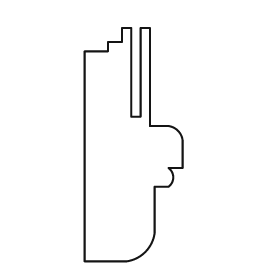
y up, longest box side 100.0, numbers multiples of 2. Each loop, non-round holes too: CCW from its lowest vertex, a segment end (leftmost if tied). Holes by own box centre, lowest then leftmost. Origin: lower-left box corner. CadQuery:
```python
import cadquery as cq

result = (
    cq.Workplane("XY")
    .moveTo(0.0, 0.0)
    .lineTo(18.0, 0.0)
    .threePointArc((26.0, 4.0), (30.0, 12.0))
    .lineTo(30.0, 32.0)
    .lineTo(36.0, 32.0)
    .threePointArc((38.0, 36.0), (36.0, 40.0))
    .lineTo(42.0, 40.0)
    .lineTo(42.0, 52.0)
    .threePointArc((40.0, 56.0), (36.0, 58.0))
    .lineTo(28.0, 58.0)
    .lineTo(28.0, 100.0)
    .lineTo(24.0, 100.0)
    .lineTo(24.0, 62.0)
    .lineTo(20.0, 62.0)
    .lineTo(20.0, 100.0)
    .lineTo(16.0, 100.0)
    .lineTo(16.0, 94.0)
    .lineTo(10.0, 94.0)
    .lineTo(10.0, 90.0)
    .lineTo(0.0, 90.0)
    .close()
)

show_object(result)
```